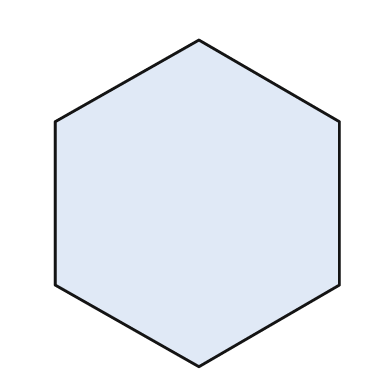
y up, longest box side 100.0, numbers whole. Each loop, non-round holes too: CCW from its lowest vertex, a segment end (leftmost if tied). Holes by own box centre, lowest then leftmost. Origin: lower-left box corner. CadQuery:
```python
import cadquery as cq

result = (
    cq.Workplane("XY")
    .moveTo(44.0, 0.0)
    .lineTo(87.0, 25.0)
    .lineTo(87.0, 75.0)
    .lineTo(44.0, 100.0)
    .lineTo(0.0, 75.0)
    .lineTo(0.0, 25.0)
    .close()
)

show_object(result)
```